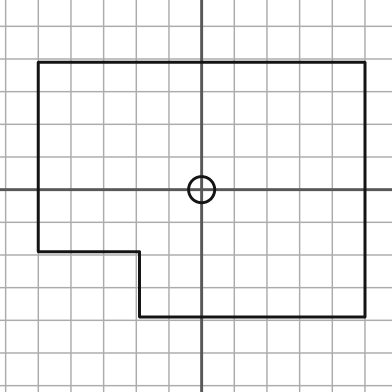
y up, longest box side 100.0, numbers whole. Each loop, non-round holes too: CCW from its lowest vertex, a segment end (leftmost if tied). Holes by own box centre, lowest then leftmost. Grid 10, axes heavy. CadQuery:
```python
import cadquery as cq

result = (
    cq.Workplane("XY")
    .moveTo(-19.0, -39.0)
    .lineTo(50.0, -39.0)
    .lineTo(50.0, 39.0)
    .lineTo(-50.0, 39.0)
    .lineTo(-50.0, -19.0)
    .lineTo(-19.0, -19.0)
    .close()
    .moveTo(0.0, 0.0)
    .circle(4.0)
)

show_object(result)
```